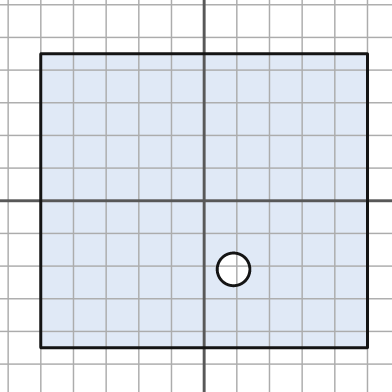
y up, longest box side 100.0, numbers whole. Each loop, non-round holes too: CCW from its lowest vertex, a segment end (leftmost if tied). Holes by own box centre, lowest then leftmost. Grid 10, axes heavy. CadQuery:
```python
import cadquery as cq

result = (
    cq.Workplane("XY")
    .moveTo(-50.0, -45.0)
    .lineTo(50.0, -45.0)
    .lineTo(50.0, 45.0)
    .lineTo(-50.0, 45.0)
    .close()
    .moveTo(9.0, -21.0)
    .circle(5.0)
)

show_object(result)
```